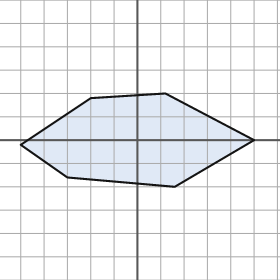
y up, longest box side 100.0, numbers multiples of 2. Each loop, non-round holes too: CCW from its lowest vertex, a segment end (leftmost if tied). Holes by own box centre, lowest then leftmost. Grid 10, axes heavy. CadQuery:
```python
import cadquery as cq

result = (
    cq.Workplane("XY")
    .moveTo(16.0, -20.0)
    .lineTo(50.0, 0.0)
    .lineTo(12.0, 20.0)
    .lineTo(-20.0, 18.0)
    .lineTo(-50.0, -2.0)
    .lineTo(-30.0, -16.0)
    .close()
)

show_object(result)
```